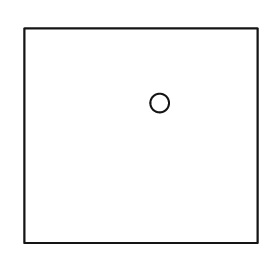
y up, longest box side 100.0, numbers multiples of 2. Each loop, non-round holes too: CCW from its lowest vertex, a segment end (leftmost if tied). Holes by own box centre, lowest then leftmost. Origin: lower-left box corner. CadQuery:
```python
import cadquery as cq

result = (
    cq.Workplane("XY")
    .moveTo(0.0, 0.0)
    .lineTo(100.0, 0.0)
    .lineTo(100.0, 92.0)
    .lineTo(0.0, 92.0)
    .close()
    .moveTo(58.0, 60.0)
    .circle(4.0)
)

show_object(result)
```